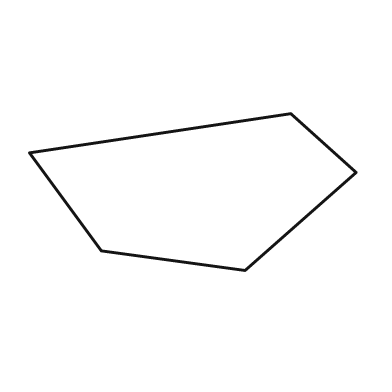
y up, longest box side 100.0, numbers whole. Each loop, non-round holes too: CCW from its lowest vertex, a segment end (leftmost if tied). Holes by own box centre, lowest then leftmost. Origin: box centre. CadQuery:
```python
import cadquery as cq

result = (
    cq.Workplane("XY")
    .moveTo(16.0, -24.0)
    .lineTo(50.0, 6.0)
    .lineTo(30.0, 24.0)
    .lineTo(-50.0, 12.0)
    .lineTo(-28.0, -18.0)
    .close()
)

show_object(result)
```